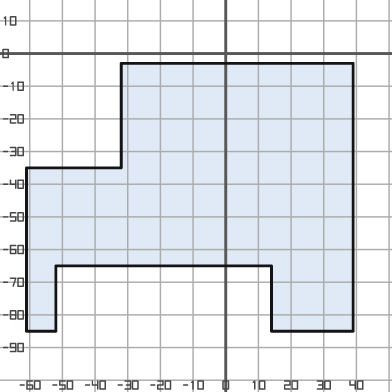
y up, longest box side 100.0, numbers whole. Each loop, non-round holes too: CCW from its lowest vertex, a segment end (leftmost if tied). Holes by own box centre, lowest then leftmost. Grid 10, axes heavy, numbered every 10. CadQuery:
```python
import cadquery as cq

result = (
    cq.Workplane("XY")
    .moveTo(-61.0, -85.0)
    .lineTo(-52.0, -85.0)
    .lineTo(-52.0, -65.0)
    .lineTo(14.0, -65.0)
    .lineTo(14.0, -85.0)
    .lineTo(39.0, -85.0)
    .lineTo(39.0, -3.0)
    .lineTo(-32.0, -3.0)
    .lineTo(-32.0, -35.0)
    .lineTo(-61.0, -35.0)
    .close()
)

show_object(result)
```